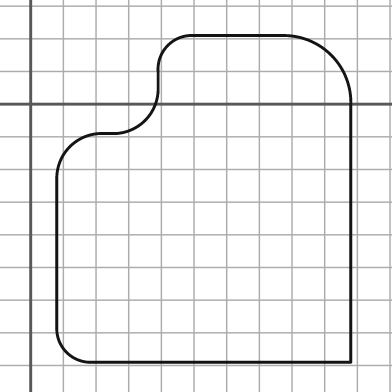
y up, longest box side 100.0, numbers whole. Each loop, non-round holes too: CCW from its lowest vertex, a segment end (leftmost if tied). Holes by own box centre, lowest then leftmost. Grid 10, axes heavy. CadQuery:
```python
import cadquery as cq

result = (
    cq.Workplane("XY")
    .moveTo(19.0, -79.0)
    .lineTo(98.0, -79.0)
    .lineTo(98.0, 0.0)
    .threePointArc((92.0, 15.0), (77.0, 21.0))
    .lineTo(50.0, 21.0)
    .threePointArc((42.0, 18.0), (39.0, 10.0))
    .lineTo(39.0, 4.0)
    .threePointArc((35.0, -5.0), (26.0, -9.0))
    .lineTo(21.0, -9.0)
    .threePointArc((12.0, -13.0), (8.0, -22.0))
    .lineTo(8.0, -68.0)
    .threePointArc((11.0, -76.0), (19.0, -79.0))
    .close()
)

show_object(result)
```